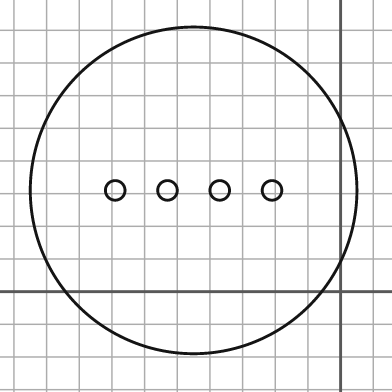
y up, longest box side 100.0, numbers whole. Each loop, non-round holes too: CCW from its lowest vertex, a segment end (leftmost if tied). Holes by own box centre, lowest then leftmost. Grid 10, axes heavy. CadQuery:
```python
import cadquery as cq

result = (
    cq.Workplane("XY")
    .moveTo(-45.0, 31.0)
    .circle(50.0)
    .moveTo(-69.0, 31.0)
    .circle(3.0)
    .moveTo(-53.0, 31.0)
    .circle(3.0)
    .moveTo(-37.0, 31.0)
    .circle(3.0)
    .moveTo(-21.0, 31.0)
    .circle(3.0)
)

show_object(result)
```